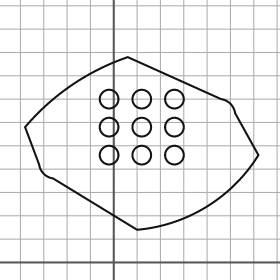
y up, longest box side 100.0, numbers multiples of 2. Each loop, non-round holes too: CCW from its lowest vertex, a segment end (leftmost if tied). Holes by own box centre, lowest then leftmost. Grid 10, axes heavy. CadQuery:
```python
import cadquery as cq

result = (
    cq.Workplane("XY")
    .moveTo(10.0, 14.0)
    .threePointArc((40.0, 24.0), (62.0, 46.0))
    .lineTo(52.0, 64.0)
    .threePointArc((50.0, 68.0), (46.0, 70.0))
    .lineTo(6.0, 88.0)
    .threePointArc((-18.0, 76.0), (-38.0, 58.0))
    .lineTo(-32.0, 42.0)
    .threePointArc((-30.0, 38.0), (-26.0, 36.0))
    .close()
    .moveTo(-2.0, 46.0)
    .circle(4.0)
    .moveTo(12.0, 46.0)
    .circle(4.0)
    .moveTo(26.0, 46.0)
    .circle(4.0)
    .moveTo(-2.0, 58.0)
    .circle(4.0)
    .moveTo(12.0, 58.0)
    .circle(4.0)
    .moveTo(26.0, 58.0)
    .circle(4.0)
    .moveTo(-2.0, 70.0)
    .circle(4.0)
    .moveTo(12.0, 70.0)
    .circle(4.0)
    .moveTo(26.0, 70.0)
    .circle(4.0)
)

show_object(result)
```